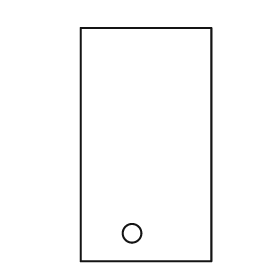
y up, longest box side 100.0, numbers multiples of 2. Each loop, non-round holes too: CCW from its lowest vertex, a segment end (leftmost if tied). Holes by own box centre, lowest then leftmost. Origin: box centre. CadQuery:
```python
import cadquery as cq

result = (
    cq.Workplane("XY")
    .moveTo(-28.0, -50.0)
    .lineTo(28.0, -50.0)
    .lineTo(28.0, 50.0)
    .lineTo(-28.0, 50.0)
    .close()
    .moveTo(-6.0, -38.0)
    .circle(4.0)
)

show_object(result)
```